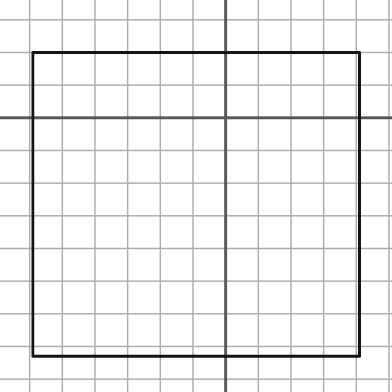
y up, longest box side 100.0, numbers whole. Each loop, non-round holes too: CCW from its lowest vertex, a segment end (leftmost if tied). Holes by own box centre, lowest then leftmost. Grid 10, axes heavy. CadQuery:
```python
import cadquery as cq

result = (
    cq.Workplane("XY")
    .moveTo(-59.0, -73.0)
    .lineTo(41.0, -73.0)
    .lineTo(41.0, 20.0)
    .lineTo(-59.0, 20.0)
    .close()
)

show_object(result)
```